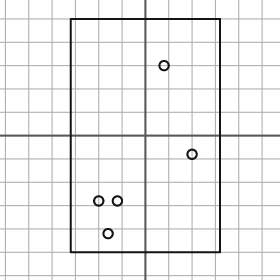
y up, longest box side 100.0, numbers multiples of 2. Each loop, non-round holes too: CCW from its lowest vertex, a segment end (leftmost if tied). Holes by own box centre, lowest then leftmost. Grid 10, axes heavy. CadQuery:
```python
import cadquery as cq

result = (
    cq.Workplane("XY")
    .moveTo(-32.0, -50.0)
    .lineTo(32.0, -50.0)
    .lineTo(32.0, 50.0)
    .lineTo(-32.0, 50.0)
    .close()
    .moveTo(-16.0, -42.0)
    .circle(2.0)
    .moveTo(-20.0, -28.0)
    .circle(2.0)
    .moveTo(-12.0, -28.0)
    .circle(2.0)
    .moveTo(20.0, -8.0)
    .circle(2.0)
    .moveTo(8.0, 30.0)
    .circle(2.0)
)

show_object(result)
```